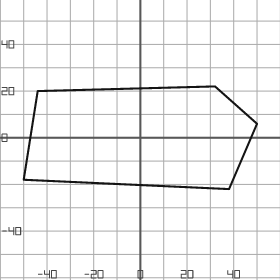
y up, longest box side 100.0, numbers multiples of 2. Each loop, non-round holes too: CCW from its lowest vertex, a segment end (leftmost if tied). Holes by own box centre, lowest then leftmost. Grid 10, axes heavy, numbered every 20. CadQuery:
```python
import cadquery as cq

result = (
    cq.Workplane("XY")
    .moveTo(38.0, -22.0)
    .lineTo(50.0, 6.0)
    .lineTo(32.0, 22.0)
    .lineTo(-44.0, 20.0)
    .lineTo(-50.0, -18.0)
    .close()
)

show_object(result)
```